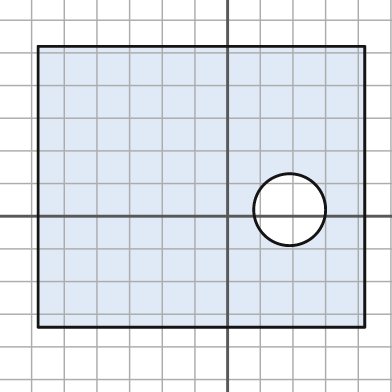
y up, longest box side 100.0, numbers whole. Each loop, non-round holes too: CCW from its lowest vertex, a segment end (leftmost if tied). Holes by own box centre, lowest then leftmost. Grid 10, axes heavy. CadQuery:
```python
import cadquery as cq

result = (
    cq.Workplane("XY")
    .moveTo(-58.0, -34.0)
    .lineTo(42.0, -34.0)
    .lineTo(42.0, 52.0)
    .lineTo(-58.0, 52.0)
    .close()
    .moveTo(19.0, 2.0)
    .circle(11.0)
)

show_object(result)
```